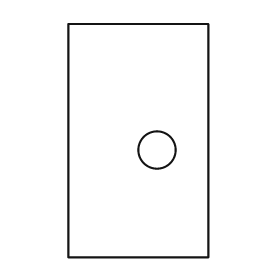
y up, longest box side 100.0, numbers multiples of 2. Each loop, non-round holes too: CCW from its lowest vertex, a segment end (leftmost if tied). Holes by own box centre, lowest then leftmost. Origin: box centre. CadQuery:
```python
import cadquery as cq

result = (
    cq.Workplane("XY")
    .moveTo(-30.0, -50.0)
    .lineTo(30.0, -50.0)
    .lineTo(30.0, 50.0)
    .lineTo(-30.0, 50.0)
    .close()
    .moveTo(8.0, -4.0)
    .circle(8.0)
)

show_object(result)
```